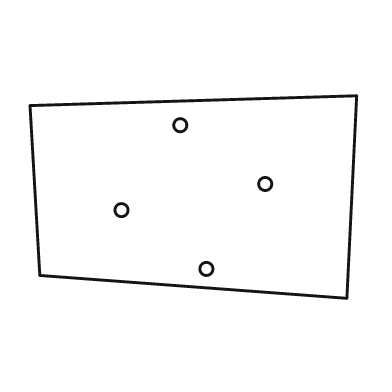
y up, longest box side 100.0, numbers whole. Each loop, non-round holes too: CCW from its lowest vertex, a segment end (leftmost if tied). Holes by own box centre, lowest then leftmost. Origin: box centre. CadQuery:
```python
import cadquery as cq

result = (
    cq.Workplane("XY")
    .moveTo(47.0, -31.0)
    .lineTo(50.0, 31.0)
    .lineTo(-50.0, 28.0)
    .lineTo(-47.0, -24.0)
    .close()
    .moveTo(4.0, -22.0)
    .circle(2.0)
    .moveTo(-22.0, -4.0)
    .circle(2.0)
    .moveTo(22.0, 4.0)
    .circle(2.0)
    .moveTo(-4.0, 22.0)
    .circle(2.0)
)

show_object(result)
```